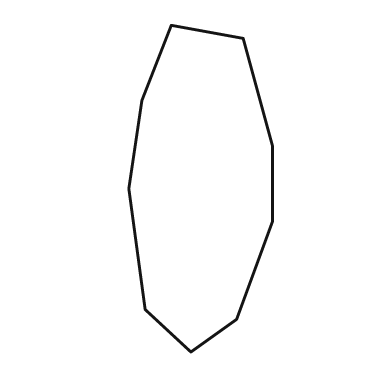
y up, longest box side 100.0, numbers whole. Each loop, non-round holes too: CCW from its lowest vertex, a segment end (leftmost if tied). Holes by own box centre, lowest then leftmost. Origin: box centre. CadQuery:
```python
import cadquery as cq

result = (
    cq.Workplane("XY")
    .moveTo(-3.0, -50.0)
    .lineTo(11.0, -40.0)
    .lineTo(22.0, -10.0)
    .lineTo(22.0, 13.0)
    .lineTo(13.0, 46.0)
    .lineTo(-9.0, 50.0)
    .lineTo(-18.0, 27.0)
    .lineTo(-22.0, 0.0)
    .lineTo(-17.0, -37.0)
    .close()
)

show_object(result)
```